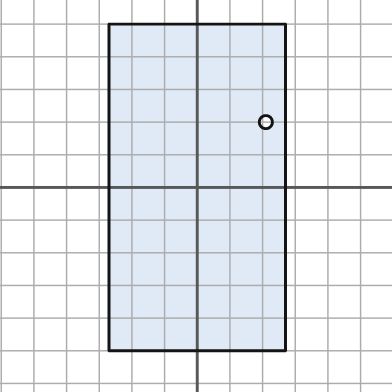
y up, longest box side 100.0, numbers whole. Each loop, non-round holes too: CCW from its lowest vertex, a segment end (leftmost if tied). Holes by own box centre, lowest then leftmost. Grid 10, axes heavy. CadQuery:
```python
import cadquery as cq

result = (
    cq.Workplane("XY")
    .moveTo(-27.0, -50.0)
    .lineTo(27.0, -50.0)
    .lineTo(27.0, 50.0)
    .lineTo(-27.0, 50.0)
    .close()
    .moveTo(21.0, 20.0)
    .circle(2.0)
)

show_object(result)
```